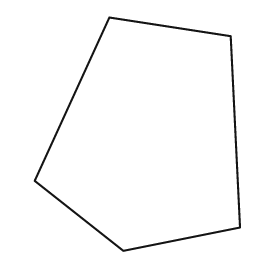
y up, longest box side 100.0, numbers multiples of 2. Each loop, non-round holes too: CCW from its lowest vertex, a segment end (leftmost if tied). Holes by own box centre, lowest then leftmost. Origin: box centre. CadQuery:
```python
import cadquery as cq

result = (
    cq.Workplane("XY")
    .moveTo(-6.0, -50.0)
    .lineTo(44.0, -40.0)
    .lineTo(40.0, 42.0)
    .lineTo(-12.0, 50.0)
    .lineTo(-44.0, -20.0)
    .close()
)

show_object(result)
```